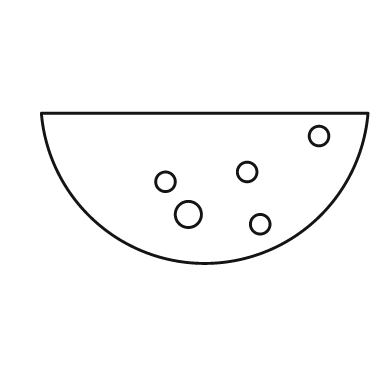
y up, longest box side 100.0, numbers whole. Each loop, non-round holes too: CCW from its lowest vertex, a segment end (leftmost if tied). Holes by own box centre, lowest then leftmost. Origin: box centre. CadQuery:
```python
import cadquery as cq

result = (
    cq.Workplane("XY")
    .moveTo(-50.0, 23.0)
    .threePointArc((0.0, -23.0), (50.0, 23.0))
    .close()
    .moveTo(17.0, -11.0)
    .circle(3.0)
    .moveTo(-5.0, -8.0)
    .circle(4.0)
    .moveTo(-12.0, 2.0)
    .circle(3.0)
    .moveTo(13.0, 5.0)
    .circle(3.0)
    .moveTo(35.0, 16.0)
    .circle(3.0)
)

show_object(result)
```